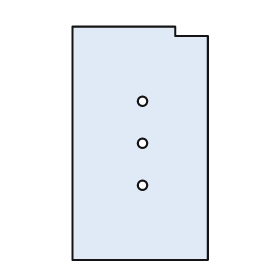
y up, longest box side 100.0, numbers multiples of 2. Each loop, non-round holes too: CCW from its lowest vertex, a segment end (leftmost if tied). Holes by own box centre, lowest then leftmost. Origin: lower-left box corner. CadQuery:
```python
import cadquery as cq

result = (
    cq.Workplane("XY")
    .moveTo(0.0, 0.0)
    .lineTo(58.0, 0.0)
    .lineTo(58.0, 96.0)
    .lineTo(44.0, 96.0)
    .lineTo(44.0, 100.0)
    .lineTo(0.0, 100.0)
    .close()
    .moveTo(30.0, 32.0)
    .circle(2.0)
    .moveTo(30.0, 50.0)
    .circle(2.0)
    .moveTo(30.0, 68.0)
    .circle(2.0)
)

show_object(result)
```